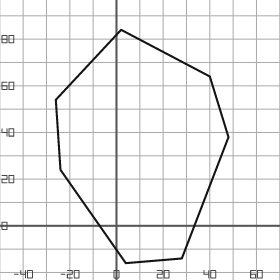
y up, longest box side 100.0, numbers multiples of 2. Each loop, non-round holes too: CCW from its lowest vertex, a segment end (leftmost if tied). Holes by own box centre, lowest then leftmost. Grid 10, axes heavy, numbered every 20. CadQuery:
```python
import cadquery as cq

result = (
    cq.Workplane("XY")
    .moveTo(4.0, -16.0)
    .lineTo(28.0, -14.0)
    .lineTo(48.0, 38.0)
    .lineTo(40.0, 64.0)
    .lineTo(2.0, 84.0)
    .lineTo(-26.0, 54.0)
    .lineTo(-24.0, 24.0)
    .close()
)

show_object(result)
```